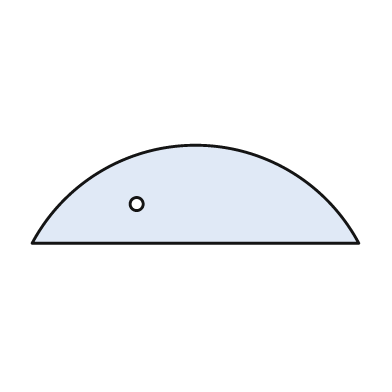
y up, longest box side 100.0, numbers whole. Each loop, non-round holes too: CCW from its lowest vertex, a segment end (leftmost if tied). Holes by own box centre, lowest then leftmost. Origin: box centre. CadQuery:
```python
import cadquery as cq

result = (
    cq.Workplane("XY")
    .moveTo(-50.0, -15.0)
    .lineTo(50.0, -15.0)
    .threePointArc((0.0, 15.0), (-50.0, -15.0))
    .close()
    .moveTo(-18.0, -3.0)
    .circle(2.0)
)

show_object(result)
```